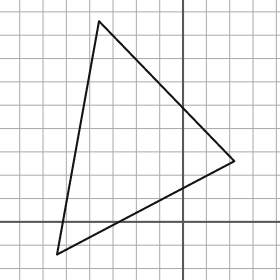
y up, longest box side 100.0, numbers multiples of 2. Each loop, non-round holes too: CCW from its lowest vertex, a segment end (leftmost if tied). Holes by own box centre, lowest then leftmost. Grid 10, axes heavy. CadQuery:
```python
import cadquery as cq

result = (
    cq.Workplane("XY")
    .moveTo(-54.0, -14.0)
    .lineTo(22.0, 26.0)
    .lineTo(-36.0, 86.0)
    .close()
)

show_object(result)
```